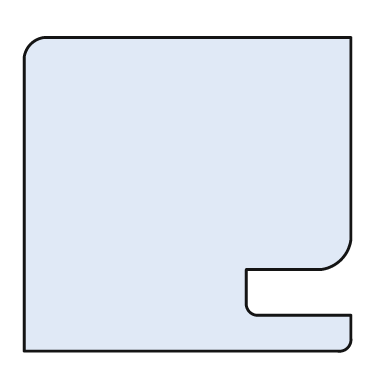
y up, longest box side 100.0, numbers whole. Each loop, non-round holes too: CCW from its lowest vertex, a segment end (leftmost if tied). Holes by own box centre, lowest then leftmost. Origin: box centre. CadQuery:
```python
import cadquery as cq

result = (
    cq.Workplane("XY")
    .moveTo(-50.0, -48.0)
    .lineTo(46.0, -48.0)
    .threePointArc((49.0, -47.0), (50.0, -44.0))
    .lineTo(50.0, -37.0)
    .lineTo(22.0, -37.0)
    .threePointArc((19.0, -36.0), (18.0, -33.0))
    .lineTo(18.0, -23.0)
    .lineTo(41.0, -23.0)
    .threePointArc((47.0, -20.0), (50.0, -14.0))
    .lineTo(50.0, 48.0)
    .lineTo(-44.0, 48.0)
    .threePointArc((-48.0, 46.0), (-50.0, 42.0))
    .close()
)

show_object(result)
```